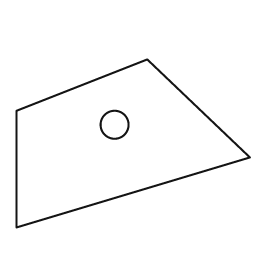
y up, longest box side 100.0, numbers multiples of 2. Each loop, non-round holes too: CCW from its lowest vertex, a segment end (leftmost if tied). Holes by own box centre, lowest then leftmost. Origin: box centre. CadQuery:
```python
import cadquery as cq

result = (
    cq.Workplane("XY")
    .moveTo(-50.0, -36.0)
    .lineTo(50.0, -6.0)
    .lineTo(6.0, 36.0)
    .lineTo(-50.0, 14.0)
    .close()
    .moveTo(-8.0, 8.0)
    .circle(6.0)
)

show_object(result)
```